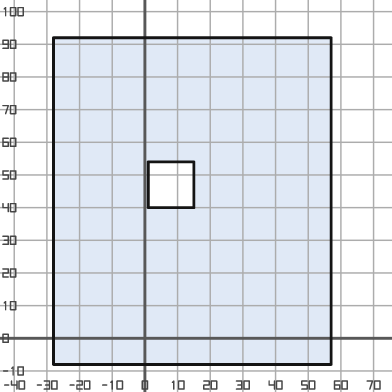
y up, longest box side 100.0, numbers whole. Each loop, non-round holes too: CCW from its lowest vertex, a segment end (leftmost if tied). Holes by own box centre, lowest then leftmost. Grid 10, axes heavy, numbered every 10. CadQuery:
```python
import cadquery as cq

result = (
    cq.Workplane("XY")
    .moveTo(-28.0, -8.0)
    .lineTo(57.0, -8.0)
    .lineTo(57.0, 92.0)
    .lineTo(-28.0, 92.0)
    .close()
    .moveTo(1.0, 40.0)
    .lineTo(15.0, 40.0)
    .lineTo(15.0, 54.0)
    .lineTo(1.0, 54.0)
    .close()
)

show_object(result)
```